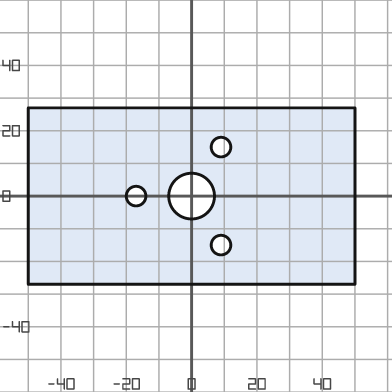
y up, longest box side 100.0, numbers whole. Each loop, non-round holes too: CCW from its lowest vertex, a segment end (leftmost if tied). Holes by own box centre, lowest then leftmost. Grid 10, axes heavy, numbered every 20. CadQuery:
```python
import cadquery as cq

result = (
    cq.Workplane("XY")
    .moveTo(-50.0, -27.0)
    .lineTo(50.0, -27.0)
    .lineTo(50.0, 27.0)
    .lineTo(-50.0, 27.0)
    .close()
    .moveTo(9.0, -15.0)
    .circle(3.0)
    .moveTo(-17.0, 0.0)
    .circle(3.0)
    .moveTo(0.0, 0.0)
    .circle(7.0)
    .moveTo(9.0, 15.0)
    .circle(3.0)
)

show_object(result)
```